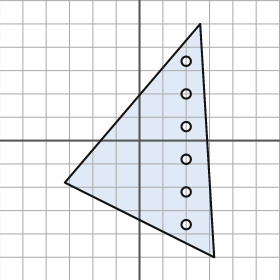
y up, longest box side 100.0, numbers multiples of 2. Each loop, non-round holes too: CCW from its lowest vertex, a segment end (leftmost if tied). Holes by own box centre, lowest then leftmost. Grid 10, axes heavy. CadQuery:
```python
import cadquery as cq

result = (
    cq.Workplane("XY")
    .moveTo(32.0, -50.0)
    .lineTo(26.0, 50.0)
    .lineTo(-32.0, -18.0)
    .close()
    .moveTo(20.0, -36.0)
    .circle(2.0)
    .moveTo(20.0, -22.0)
    .circle(2.0)
    .moveTo(20.0, -8.0)
    .circle(2.0)
    .moveTo(20.0, 6.0)
    .circle(2.0)
    .moveTo(20.0, 20.0)
    .circle(2.0)
    .moveTo(20.0, 34.0)
    .circle(2.0)
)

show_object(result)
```